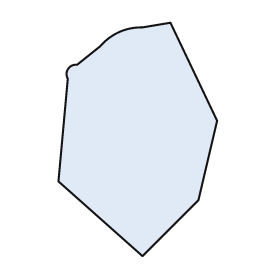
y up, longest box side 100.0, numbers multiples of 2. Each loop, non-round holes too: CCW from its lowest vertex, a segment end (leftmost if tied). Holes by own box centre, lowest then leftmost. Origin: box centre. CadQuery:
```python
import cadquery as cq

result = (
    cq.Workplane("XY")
    .moveTo(2.0, -50.0)
    .lineTo(26.0, -26.0)
    .lineTo(34.0, 8.0)
    .lineTo(14.0, 50.0)
    .lineTo(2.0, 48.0)
    .threePointArc((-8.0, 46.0), (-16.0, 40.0))
    .lineTo(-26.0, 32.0)
    .threePointArc((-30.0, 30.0), (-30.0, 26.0))
    .lineTo(-34.0, -18.0)
    .close()
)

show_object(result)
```